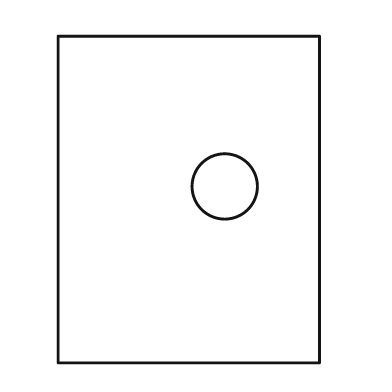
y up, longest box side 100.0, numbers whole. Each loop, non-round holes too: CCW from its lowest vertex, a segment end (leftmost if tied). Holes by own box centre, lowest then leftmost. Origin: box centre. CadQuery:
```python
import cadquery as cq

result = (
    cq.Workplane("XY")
    .moveTo(-40.0, -50.0)
    .lineTo(40.0, -50.0)
    .lineTo(40.0, 50.0)
    .lineTo(-40.0, 50.0)
    .close()
    .moveTo(11.0, 4.0)
    .circle(10.0)
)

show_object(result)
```